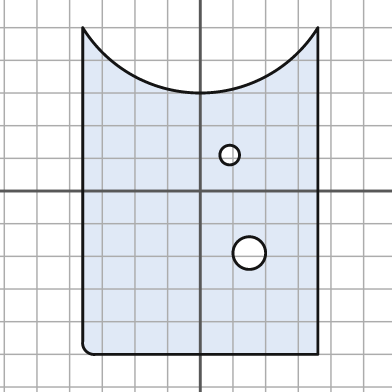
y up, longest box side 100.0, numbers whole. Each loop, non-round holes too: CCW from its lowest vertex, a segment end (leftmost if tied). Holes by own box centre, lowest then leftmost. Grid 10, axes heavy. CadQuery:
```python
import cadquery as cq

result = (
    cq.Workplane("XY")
    .moveTo(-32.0, -50.0)
    .lineTo(36.0, -50.0)
    .lineTo(36.0, 50.0)
    .threePointArc((0.0, 30.0), (-36.0, 50.0))
    .lineTo(-36.0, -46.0)
    .threePointArc((-35.0, -49.0), (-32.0, -50.0))
    .close()
    .moveTo(15.0, -19.0)
    .circle(5.0)
    .moveTo(9.0, 11.0)
    .circle(3.0)
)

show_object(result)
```